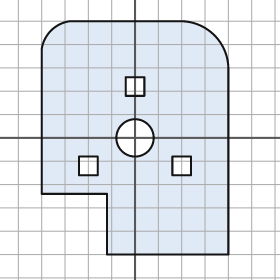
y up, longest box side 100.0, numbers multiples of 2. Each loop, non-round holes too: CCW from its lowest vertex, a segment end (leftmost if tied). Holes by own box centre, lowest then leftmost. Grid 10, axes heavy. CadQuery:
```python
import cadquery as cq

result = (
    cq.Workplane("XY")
    .moveTo(-12.0, -50.0)
    .lineTo(40.0, -50.0)
    .lineTo(40.0, 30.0)
    .threePointArc((34.0, 44.0), (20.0, 50.0))
    .lineTo(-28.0, 50.0)
    .threePointArc((-36.0, 46.0), (-40.0, 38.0))
    .lineTo(-40.0, -24.0)
    .lineTo(-12.0, -24.0)
    .close()
    .moveTo(-24.0, -16.0)
    .lineTo(-16.0, -16.0)
    .lineTo(-16.0, -8.0)
    .lineTo(-24.0, -8.0)
    .close()
    .moveTo(16.0, -16.0)
    .lineTo(24.0, -16.0)
    .lineTo(24.0, -8.0)
    .lineTo(16.0, -8.0)
    .close()
    .moveTo(0.0, 0.0)
    .circle(8.0)
    .moveTo(-4.0, 18.0)
    .lineTo(4.0, 18.0)
    .lineTo(4.0, 26.0)
    .lineTo(-4.0, 26.0)
    .close()
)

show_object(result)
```